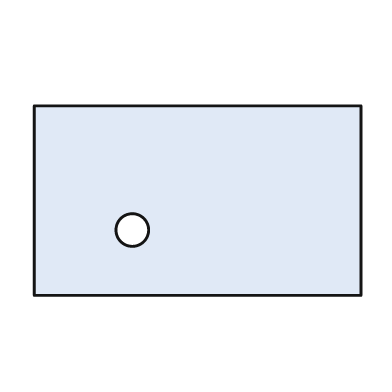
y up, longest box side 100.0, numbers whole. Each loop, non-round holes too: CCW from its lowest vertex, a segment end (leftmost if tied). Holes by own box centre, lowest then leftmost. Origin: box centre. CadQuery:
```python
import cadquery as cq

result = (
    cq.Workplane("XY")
    .moveTo(-50.0, -29.0)
    .lineTo(50.0, -29.0)
    .lineTo(50.0, 29.0)
    .lineTo(-50.0, 29.0)
    .close()
    .moveTo(-20.0, -9.0)
    .circle(5.0)
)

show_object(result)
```